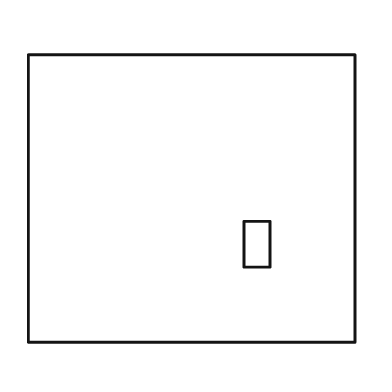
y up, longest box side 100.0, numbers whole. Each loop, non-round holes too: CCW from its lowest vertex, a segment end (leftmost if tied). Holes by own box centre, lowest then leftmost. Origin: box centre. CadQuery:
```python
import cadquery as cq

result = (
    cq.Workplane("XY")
    .moveTo(-50.0, -44.0)
    .lineTo(50.0, -44.0)
    .lineTo(50.0, 44.0)
    .lineTo(-50.0, 44.0)
    .close()
    .moveTo(16.0, -21.0)
    .lineTo(24.0, -21.0)
    .lineTo(24.0, -7.0)
    .lineTo(16.0, -7.0)
    .close()
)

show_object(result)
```